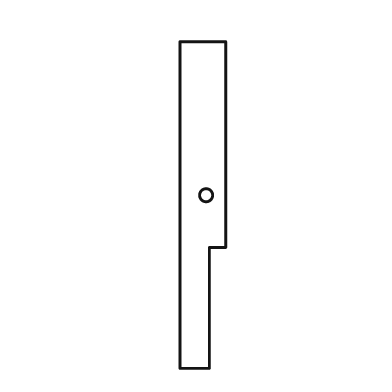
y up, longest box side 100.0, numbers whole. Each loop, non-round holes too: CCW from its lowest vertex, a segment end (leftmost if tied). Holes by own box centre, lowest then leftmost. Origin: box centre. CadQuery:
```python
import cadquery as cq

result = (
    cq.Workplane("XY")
    .moveTo(-7.0, -50.0)
    .lineTo(2.0, -50.0)
    .lineTo(2.0, -13.0)
    .lineTo(7.0, -13.0)
    .lineTo(7.0, 50.0)
    .lineTo(-7.0, 50.0)
    .close()
    .moveTo(1.0, 3.0)
    .circle(2.0)
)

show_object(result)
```